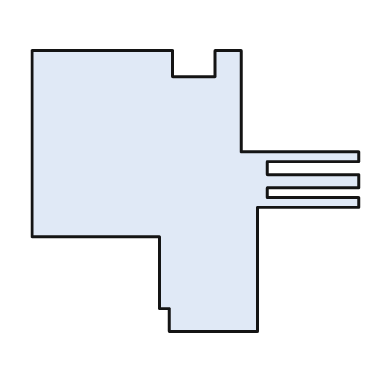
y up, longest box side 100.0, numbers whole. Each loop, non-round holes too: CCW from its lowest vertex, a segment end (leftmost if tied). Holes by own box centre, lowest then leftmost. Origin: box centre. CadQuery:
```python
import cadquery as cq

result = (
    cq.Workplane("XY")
    .moveTo(-8.0, -43.0)
    .lineTo(19.0, -43.0)
    .lineTo(19.0, -5.0)
    .lineTo(50.0, -5.0)
    .lineTo(50.0, -2.0)
    .lineTo(22.0, -2.0)
    .lineTo(22.0, 1.0)
    .lineTo(50.0, 1.0)
    .lineTo(50.0, 5.0)
    .lineTo(22.0, 5.0)
    .lineTo(22.0, 9.0)
    .lineTo(50.0, 9.0)
    .lineTo(50.0, 12.0)
    .lineTo(14.0, 12.0)
    .lineTo(14.0, 43.0)
    .lineTo(6.0, 43.0)
    .lineTo(6.0, 35.0)
    .lineTo(-7.0, 35.0)
    .lineTo(-7.0, 43.0)
    .lineTo(-50.0, 43.0)
    .lineTo(-50.0, -14.0)
    .lineTo(-11.0, -14.0)
    .lineTo(-11.0, -36.0)
    .lineTo(-8.0, -36.0)
    .close()
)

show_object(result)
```